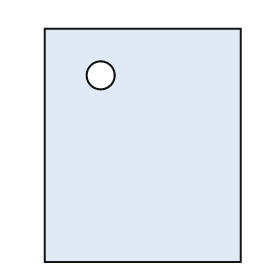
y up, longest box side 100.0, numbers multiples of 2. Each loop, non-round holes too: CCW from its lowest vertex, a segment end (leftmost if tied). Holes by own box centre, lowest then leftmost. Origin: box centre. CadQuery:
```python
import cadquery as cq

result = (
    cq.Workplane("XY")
    .moveTo(-42.0, -50.0)
    .lineTo(42.0, -50.0)
    .lineTo(42.0, 50.0)
    .lineTo(-42.0, 50.0)
    .close()
    .moveTo(-18.0, 30.0)
    .circle(6.0)
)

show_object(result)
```